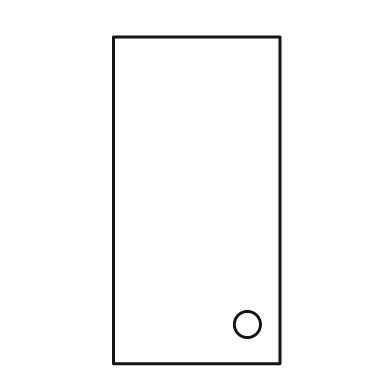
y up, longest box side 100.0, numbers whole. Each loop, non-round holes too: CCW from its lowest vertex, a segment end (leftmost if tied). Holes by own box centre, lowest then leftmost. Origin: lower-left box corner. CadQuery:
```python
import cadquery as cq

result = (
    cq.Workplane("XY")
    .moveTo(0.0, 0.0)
    .lineTo(51.0, 0.0)
    .lineTo(51.0, 100.0)
    .lineTo(0.0, 100.0)
    .close()
    .moveTo(41.0, 12.0)
    .circle(4.0)
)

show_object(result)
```